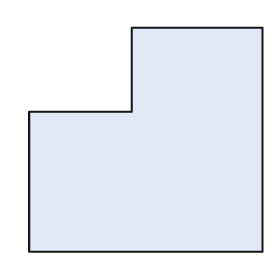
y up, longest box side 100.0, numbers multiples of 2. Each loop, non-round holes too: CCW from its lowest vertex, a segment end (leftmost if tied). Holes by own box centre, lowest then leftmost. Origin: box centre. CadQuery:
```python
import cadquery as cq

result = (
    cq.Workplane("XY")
    .moveTo(-50.0, -48.0)
    .lineTo(50.0, -48.0)
    .lineTo(50.0, 48.0)
    .lineTo(-6.0, 48.0)
    .lineTo(-6.0, 12.0)
    .lineTo(-50.0, 12.0)
    .close()
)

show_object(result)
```